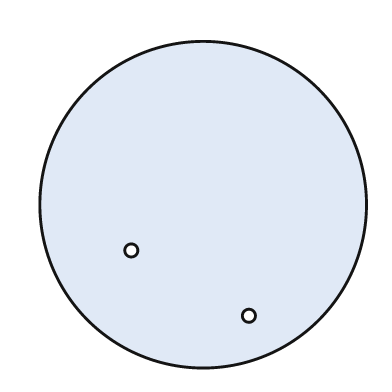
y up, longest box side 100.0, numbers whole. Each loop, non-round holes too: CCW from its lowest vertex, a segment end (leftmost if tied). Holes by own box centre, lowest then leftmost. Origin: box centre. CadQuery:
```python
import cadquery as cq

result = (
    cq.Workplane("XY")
    .moveTo(0.0, 0.0)
    .circle(50.0)
    .moveTo(14.0, -34.0)
    .circle(2.0)
    .moveTo(-22.0, -14.0)
    .circle(2.0)
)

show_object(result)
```